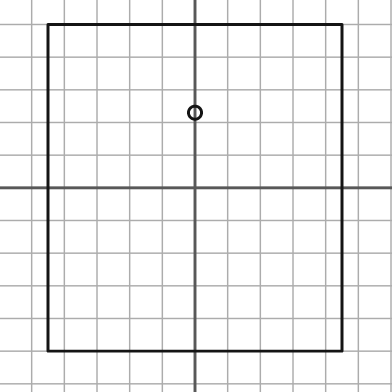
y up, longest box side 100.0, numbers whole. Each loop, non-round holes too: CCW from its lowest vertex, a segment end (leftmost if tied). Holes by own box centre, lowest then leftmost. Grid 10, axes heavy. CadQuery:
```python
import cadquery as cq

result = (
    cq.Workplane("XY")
    .moveTo(-45.0, -50.0)
    .lineTo(45.0, -50.0)
    .lineTo(45.0, 50.0)
    .lineTo(-45.0, 50.0)
    .close()
    .moveTo(0.0, 23.0)
    .circle(2.0)
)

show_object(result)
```